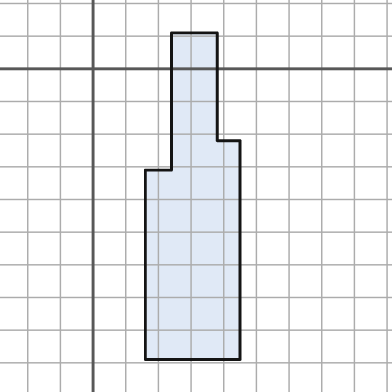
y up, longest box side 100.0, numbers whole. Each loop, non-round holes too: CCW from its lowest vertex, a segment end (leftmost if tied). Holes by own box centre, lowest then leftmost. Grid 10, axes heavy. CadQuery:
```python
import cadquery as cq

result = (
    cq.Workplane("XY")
    .moveTo(16.0, -89.0)
    .lineTo(45.0, -89.0)
    .lineTo(45.0, -22.0)
    .lineTo(38.0, -22.0)
    .lineTo(38.0, 11.0)
    .lineTo(24.0, 11.0)
    .lineTo(24.0, -31.0)
    .lineTo(16.0, -31.0)
    .close()
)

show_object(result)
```